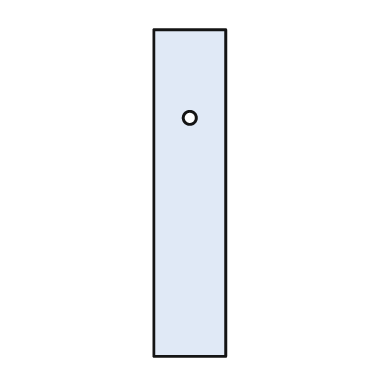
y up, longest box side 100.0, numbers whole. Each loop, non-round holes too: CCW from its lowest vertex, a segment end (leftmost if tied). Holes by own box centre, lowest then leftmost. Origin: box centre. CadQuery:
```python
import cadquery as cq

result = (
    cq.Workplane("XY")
    .moveTo(-11.0, -50.0)
    .lineTo(11.0, -50.0)
    .lineTo(11.0, 50.0)
    .lineTo(-11.0, 50.0)
    .close()
    .moveTo(0.0, 23.0)
    .circle(2.0)
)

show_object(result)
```